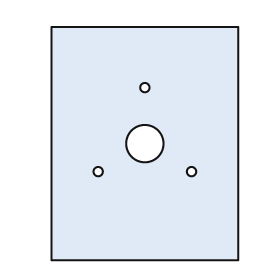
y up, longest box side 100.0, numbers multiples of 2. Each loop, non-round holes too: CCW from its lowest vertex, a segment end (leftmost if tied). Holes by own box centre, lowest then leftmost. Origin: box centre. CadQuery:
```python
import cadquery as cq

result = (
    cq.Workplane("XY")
    .moveTo(-40.0, -50.0)
    .lineTo(40.0, -50.0)
    .lineTo(40.0, 50.0)
    .lineTo(-40.0, 50.0)
    .close()
    .moveTo(-20.0, -12.0)
    .circle(2.0)
    .moveTo(20.0, -12.0)
    .circle(2.0)
    .moveTo(0.0, 0.0)
    .circle(8.0)
    .moveTo(0.0, 24.0)
    .circle(2.0)
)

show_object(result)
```